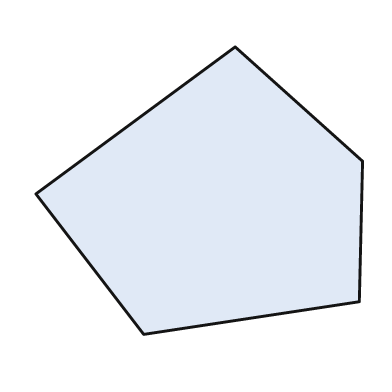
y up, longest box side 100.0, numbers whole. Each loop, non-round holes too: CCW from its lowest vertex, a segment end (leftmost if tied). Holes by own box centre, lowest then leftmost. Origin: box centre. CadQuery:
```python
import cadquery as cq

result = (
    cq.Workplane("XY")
    .moveTo(-17.0, -44.0)
    .lineTo(49.0, -34.0)
    .lineTo(50.0, 9.0)
    .lineTo(11.0, 44.0)
    .lineTo(-50.0, -1.0)
    .close()
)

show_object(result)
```